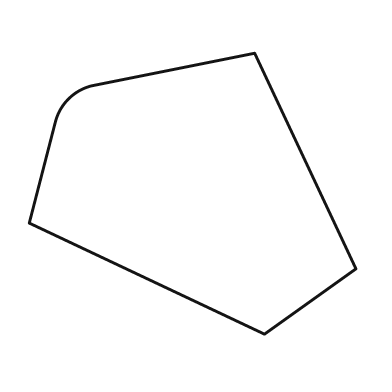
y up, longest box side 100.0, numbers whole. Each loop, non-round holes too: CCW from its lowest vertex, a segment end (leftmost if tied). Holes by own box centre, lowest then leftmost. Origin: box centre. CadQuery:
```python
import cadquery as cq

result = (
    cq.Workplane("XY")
    .moveTo(22.0, -43.0)
    .lineTo(50.0, -23.0)
    .lineTo(19.0, 43.0)
    .lineTo(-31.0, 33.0)
    .threePointArc((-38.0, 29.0), (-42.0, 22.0))
    .lineTo(-50.0, -9.0)
    .close()
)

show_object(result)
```